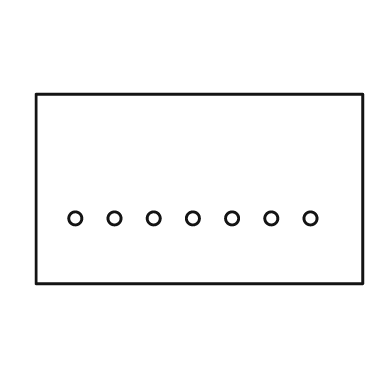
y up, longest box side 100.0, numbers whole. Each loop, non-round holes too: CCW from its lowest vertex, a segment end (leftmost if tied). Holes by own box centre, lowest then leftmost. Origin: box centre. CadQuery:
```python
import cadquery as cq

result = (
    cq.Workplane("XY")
    .moveTo(-50.0, -29.0)
    .lineTo(50.0, -29.0)
    .lineTo(50.0, 29.0)
    .lineTo(-50.0, 29.0)
    .close()
    .moveTo(-38.0, -9.0)
    .circle(2.0)
    .moveTo(-26.0, -9.0)
    .circle(2.0)
    .moveTo(-14.0, -9.0)
    .circle(2.0)
    .moveTo(-2.0, -9.0)
    .circle(2.0)
    .moveTo(10.0, -9.0)
    .circle(2.0)
    .moveTo(22.0, -9.0)
    .circle(2.0)
    .moveTo(34.0, -9.0)
    .circle(2.0)
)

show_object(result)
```